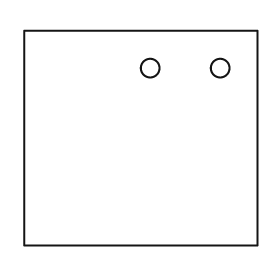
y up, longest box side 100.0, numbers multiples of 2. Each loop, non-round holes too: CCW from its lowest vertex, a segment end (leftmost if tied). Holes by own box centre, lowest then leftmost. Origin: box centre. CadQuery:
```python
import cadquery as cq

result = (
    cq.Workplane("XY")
    .moveTo(-50.0, -46.0)
    .lineTo(50.0, -46.0)
    .lineTo(50.0, 46.0)
    .lineTo(-50.0, 46.0)
    .close()
    .moveTo(4.0, 30.0)
    .circle(4.0)
    .moveTo(34.0, 30.0)
    .circle(4.0)
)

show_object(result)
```